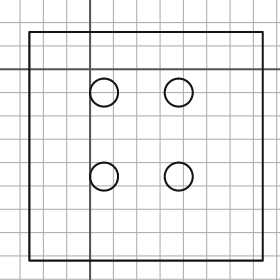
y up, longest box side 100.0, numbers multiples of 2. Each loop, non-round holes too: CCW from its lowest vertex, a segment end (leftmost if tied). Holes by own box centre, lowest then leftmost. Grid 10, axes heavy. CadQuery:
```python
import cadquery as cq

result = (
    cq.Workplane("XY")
    .moveTo(-26.0, -82.0)
    .lineTo(74.0, -82.0)
    .lineTo(74.0, 16.0)
    .lineTo(-26.0, 16.0)
    .close()
    .moveTo(6.0, -46.0)
    .circle(6.0)
    .moveTo(38.0, -46.0)
    .circle(6.0)
    .moveTo(6.0, -10.0)
    .circle(6.0)
    .moveTo(38.0, -10.0)
    .circle(6.0)
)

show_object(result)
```